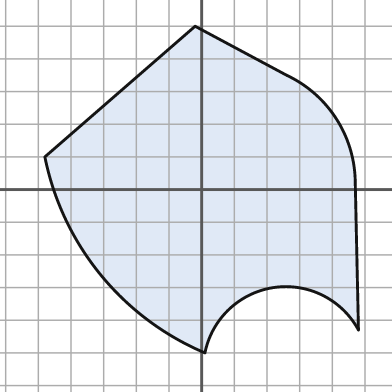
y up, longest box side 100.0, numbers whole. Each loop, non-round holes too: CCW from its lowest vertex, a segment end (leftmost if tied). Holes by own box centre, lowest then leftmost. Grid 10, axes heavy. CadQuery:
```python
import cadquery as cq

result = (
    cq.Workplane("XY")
    .moveTo(1.0, -50.0)
    .threePointArc((22.0, -30.0), (48.0, -43.0))
    .lineTo(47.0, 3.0)
    .threePointArc((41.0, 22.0), (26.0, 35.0))
    .lineTo(-2.0, 50.0)
    .lineTo(-48.0, 10.0)
    .threePointArc((-31.0, -26.0), (1.0, -50.0))
    .close()
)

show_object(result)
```